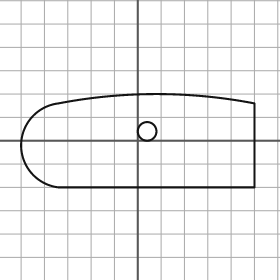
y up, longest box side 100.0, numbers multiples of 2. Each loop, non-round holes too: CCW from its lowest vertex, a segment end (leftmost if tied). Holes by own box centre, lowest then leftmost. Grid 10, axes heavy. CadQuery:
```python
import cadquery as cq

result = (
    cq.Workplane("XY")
    .moveTo(-34.0, -20.0)
    .lineTo(50.0, -20.0)
    .lineTo(50.0, 16.0)
    .threePointArc((8.0, 20.0), (-34.0, 16.0))
    .threePointArc((-50.0, -2.0), (-34.0, -20.0))
    .close()
    .moveTo(4.0, 4.0)
    .circle(4.0)
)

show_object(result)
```